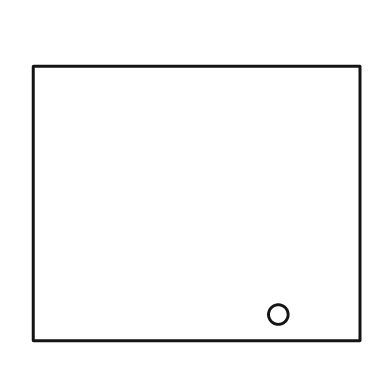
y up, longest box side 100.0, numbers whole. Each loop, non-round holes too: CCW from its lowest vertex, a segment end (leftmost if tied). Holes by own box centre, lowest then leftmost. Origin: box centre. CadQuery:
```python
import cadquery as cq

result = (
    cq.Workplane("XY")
    .moveTo(-50.0, -42.0)
    .lineTo(50.0, -42.0)
    .lineTo(50.0, 42.0)
    .lineTo(-50.0, 42.0)
    .close()
    .moveTo(25.0, -34.0)
    .circle(3.0)
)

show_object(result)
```